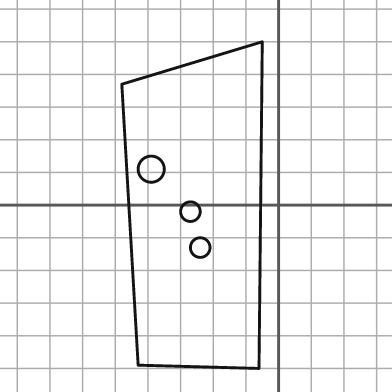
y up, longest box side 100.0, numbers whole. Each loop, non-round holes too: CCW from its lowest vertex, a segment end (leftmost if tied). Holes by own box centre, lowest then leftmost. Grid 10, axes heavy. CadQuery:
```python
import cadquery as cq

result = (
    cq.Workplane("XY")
    .moveTo(-6.0, -50.0)
    .lineTo(-5.0, 50.0)
    .lineTo(-48.0, 37.0)
    .lineTo(-43.0, -49.0)
    .close()
    .moveTo(-24.0, -13.0)
    .circle(3.0)
    .moveTo(-27.0, -2.0)
    .circle(3.0)
    .moveTo(-39.0, 11.0)
    .circle(4.0)
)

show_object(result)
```